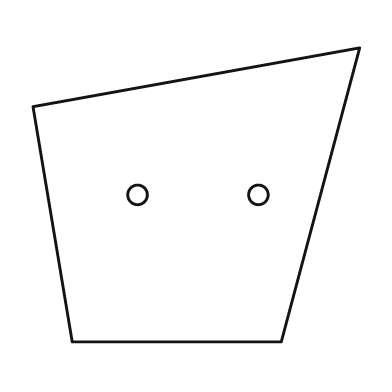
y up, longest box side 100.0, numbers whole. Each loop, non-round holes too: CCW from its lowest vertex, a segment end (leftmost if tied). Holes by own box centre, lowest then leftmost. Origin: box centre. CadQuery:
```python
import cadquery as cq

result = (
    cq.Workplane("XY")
    .moveTo(-38.0, -45.0)
    .lineTo(26.0, -45.0)
    .lineTo(50.0, 45.0)
    .lineTo(-50.0, 27.0)
    .close()
    .moveTo(-18.0, 0.0)
    .circle(3.0)
    .moveTo(19.0, 0.0)
    .circle(3.0)
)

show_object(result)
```